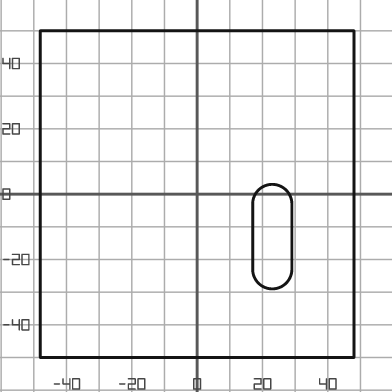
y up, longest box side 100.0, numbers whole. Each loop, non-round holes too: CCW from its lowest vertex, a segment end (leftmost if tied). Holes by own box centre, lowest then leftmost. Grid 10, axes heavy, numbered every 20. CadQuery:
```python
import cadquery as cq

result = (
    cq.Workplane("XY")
    .moveTo(-48.0, -50.0)
    .lineTo(48.0, -50.0)
    .lineTo(48.0, 50.0)
    .lineTo(-48.0, 50.0)
    .close()
    .moveTo(17.0, -23.0)
    .threePointArc((23.0, -29.0), (29.0, -23.0))
    .lineTo(29.0, -3.0)
    .threePointArc((23.0, 3.0), (17.0, -3.0))
    .close()
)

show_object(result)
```